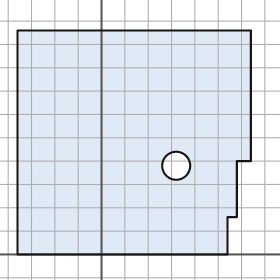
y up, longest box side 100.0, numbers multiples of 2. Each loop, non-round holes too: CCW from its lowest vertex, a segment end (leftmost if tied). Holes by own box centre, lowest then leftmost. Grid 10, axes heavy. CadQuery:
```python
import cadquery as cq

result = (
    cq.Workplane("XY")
    .moveTo(-36.0, 0.0)
    .lineTo(54.0, 0.0)
    .lineTo(54.0, 16.0)
    .lineTo(58.0, 16.0)
    .lineTo(58.0, 40.0)
    .lineTo(64.0, 40.0)
    .lineTo(64.0, 96.0)
    .lineTo(-36.0, 96.0)
    .close()
    .moveTo(32.0, 38.0)
    .circle(6.0)
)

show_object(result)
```